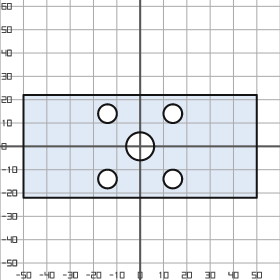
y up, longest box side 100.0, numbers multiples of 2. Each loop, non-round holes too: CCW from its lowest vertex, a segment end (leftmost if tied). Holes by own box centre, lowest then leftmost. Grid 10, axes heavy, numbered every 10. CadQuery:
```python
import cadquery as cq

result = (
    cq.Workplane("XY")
    .moveTo(-50.0, -22.0)
    .lineTo(50.0, -22.0)
    .lineTo(50.0, 22.0)
    .lineTo(-50.0, 22.0)
    .close()
    .moveTo(-14.0, -14.0)
    .circle(4.0)
    .moveTo(14.0, -14.0)
    .circle(4.0)
    .moveTo(0.0, 0.0)
    .circle(6.0)
    .moveTo(-14.0, 14.0)
    .circle(4.0)
    .moveTo(14.0, 14.0)
    .circle(4.0)
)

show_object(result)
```